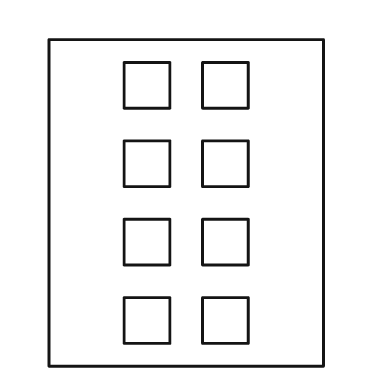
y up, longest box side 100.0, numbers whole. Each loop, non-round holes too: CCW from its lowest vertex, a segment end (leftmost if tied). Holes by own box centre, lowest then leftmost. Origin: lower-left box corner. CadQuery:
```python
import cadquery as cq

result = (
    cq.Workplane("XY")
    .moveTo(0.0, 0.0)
    .lineTo(84.0, 0.0)
    .lineTo(84.0, 100.0)
    .lineTo(0.0, 100.0)
    .close()
    .moveTo(23.0, 7.0)
    .lineTo(37.0, 7.0)
    .lineTo(37.0, 21.0)
    .lineTo(23.0, 21.0)
    .close()
    .moveTo(47.0, 7.0)
    .lineTo(61.0, 7.0)
    .lineTo(61.0, 21.0)
    .lineTo(47.0, 21.0)
    .close()
    .moveTo(23.0, 31.0)
    .lineTo(37.0, 31.0)
    .lineTo(37.0, 45.0)
    .lineTo(23.0, 45.0)
    .close()
    .moveTo(47.0, 31.0)
    .lineTo(61.0, 31.0)
    .lineTo(61.0, 45.0)
    .lineTo(47.0, 45.0)
    .close()
    .moveTo(23.0, 55.0)
    .lineTo(37.0, 55.0)
    .lineTo(37.0, 69.0)
    .lineTo(23.0, 69.0)
    .close()
    .moveTo(47.0, 55.0)
    .lineTo(61.0, 55.0)
    .lineTo(61.0, 69.0)
    .lineTo(47.0, 69.0)
    .close()
    .moveTo(23.0, 79.0)
    .lineTo(37.0, 79.0)
    .lineTo(37.0, 93.0)
    .lineTo(23.0, 93.0)
    .close()
    .moveTo(47.0, 79.0)
    .lineTo(61.0, 79.0)
    .lineTo(61.0, 93.0)
    .lineTo(47.0, 93.0)
    .close()
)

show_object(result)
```